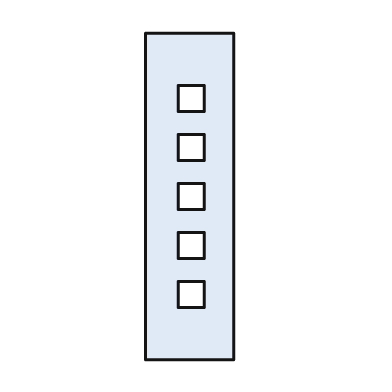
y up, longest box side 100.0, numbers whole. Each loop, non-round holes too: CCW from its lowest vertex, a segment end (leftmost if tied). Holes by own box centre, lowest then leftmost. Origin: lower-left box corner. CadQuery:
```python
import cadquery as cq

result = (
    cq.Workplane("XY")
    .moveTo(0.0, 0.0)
    .lineTo(27.0, 0.0)
    .lineTo(27.0, 100.0)
    .lineTo(0.0, 100.0)
    .close()
    .moveTo(10.0, 16.0)
    .lineTo(18.0, 16.0)
    .lineTo(18.0, 24.0)
    .lineTo(10.0, 24.0)
    .close()
    .moveTo(10.0, 31.0)
    .lineTo(18.0, 31.0)
    .lineTo(18.0, 39.0)
    .lineTo(10.0, 39.0)
    .close()
    .moveTo(10.0, 46.0)
    .lineTo(18.0, 46.0)
    .lineTo(18.0, 54.0)
    .lineTo(10.0, 54.0)
    .close()
    .moveTo(10.0, 61.0)
    .lineTo(18.0, 61.0)
    .lineTo(18.0, 69.0)
    .lineTo(10.0, 69.0)
    .close()
    .moveTo(10.0, 76.0)
    .lineTo(18.0, 76.0)
    .lineTo(18.0, 84.0)
    .lineTo(10.0, 84.0)
    .close()
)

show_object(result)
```